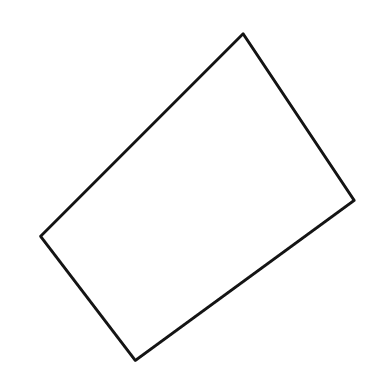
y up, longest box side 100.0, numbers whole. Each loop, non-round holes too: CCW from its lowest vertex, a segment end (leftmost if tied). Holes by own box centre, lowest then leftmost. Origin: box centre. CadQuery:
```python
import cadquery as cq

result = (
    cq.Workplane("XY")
    .moveTo(-19.0, -50.0)
    .lineTo(48.0, -1.0)
    .lineTo(14.0, 50.0)
    .lineTo(-48.0, -12.0)
    .close()
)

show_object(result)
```